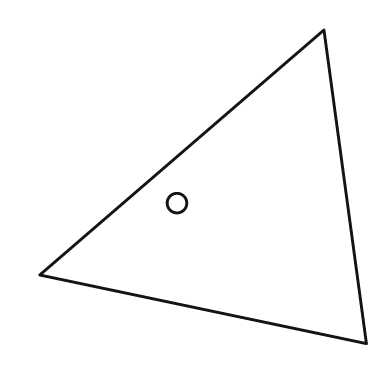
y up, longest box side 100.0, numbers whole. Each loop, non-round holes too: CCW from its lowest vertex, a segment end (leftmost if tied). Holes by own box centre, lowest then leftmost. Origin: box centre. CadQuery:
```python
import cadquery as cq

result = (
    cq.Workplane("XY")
    .moveTo(50.0, -48.0)
    .lineTo(37.0, 48.0)
    .lineTo(-50.0, -27.0)
    .close()
    .moveTo(-8.0, -5.0)
    .circle(3.0)
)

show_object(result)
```